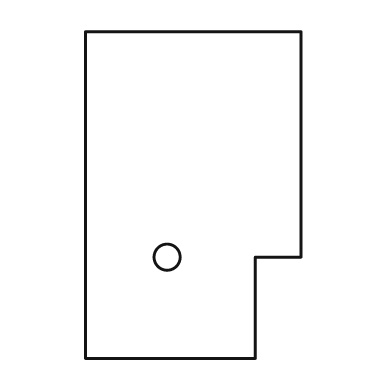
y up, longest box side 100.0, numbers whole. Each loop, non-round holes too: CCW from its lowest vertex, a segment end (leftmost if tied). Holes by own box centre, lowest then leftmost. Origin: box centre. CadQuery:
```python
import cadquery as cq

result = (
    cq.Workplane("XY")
    .moveTo(-33.0, -50.0)
    .lineTo(19.0, -50.0)
    .lineTo(19.0, -19.0)
    .lineTo(33.0, -19.0)
    .lineTo(33.0, 50.0)
    .lineTo(-33.0, 50.0)
    .close()
    .moveTo(-8.0, -19.0)
    .circle(4.0)
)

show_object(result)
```